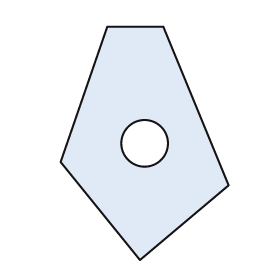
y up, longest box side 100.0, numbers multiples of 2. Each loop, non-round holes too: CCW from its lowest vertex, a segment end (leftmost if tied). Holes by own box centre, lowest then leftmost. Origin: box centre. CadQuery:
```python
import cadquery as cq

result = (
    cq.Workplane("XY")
    .moveTo(-2.0, -50.0)
    .lineTo(36.0, -18.0)
    .lineTo(8.0, 50.0)
    .lineTo(-16.0, 50.0)
    .lineTo(-36.0, -8.0)
    .close()
    .moveTo(0.0, 0.0)
    .circle(10.0)
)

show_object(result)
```